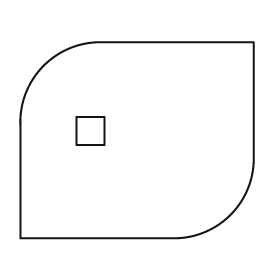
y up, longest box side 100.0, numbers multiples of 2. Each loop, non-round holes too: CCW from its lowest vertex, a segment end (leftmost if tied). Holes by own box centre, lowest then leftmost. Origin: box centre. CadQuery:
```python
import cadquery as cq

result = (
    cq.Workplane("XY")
    .moveTo(-50.0, -42.0)
    .lineTo(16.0, -42.0)
    .threePointArc((40.0, -32.0), (50.0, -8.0))
    .lineTo(50.0, 42.0)
    .lineTo(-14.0, 42.0)
    .threePointArc((-40.0, 32.0), (-50.0, 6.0))
    .close()
    .moveTo(-26.0, -2.0)
    .lineTo(-14.0, -2.0)
    .lineTo(-14.0, 10.0)
    .lineTo(-26.0, 10.0)
    .close()
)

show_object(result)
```